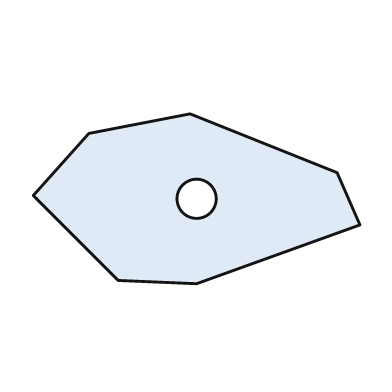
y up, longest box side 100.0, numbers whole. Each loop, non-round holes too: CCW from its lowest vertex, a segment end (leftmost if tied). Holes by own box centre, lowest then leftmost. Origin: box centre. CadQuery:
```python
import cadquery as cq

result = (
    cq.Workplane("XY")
    .moveTo(0.0, -26.0)
    .lineTo(50.0, -8.0)
    .lineTo(43.0, 8.0)
    .lineTo(-2.0, 26.0)
    .lineTo(-33.0, 20.0)
    .lineTo(-50.0, 1.0)
    .lineTo(-24.0, -25.0)
    .close()
    .moveTo(0.0, 0.0)
    .circle(6.0)
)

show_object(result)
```